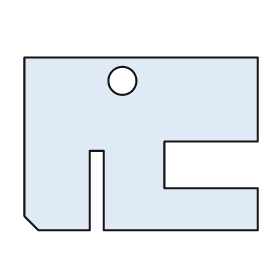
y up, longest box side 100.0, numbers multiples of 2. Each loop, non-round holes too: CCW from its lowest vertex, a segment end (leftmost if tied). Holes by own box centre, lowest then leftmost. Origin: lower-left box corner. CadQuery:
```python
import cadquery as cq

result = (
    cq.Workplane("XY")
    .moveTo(6.0, 0.0)
    .lineTo(28.0, 0.0)
    .lineTo(28.0, 34.0)
    .lineTo(34.0, 34.0)
    .lineTo(34.0, 0.0)
    .lineTo(100.0, 0.0)
    .lineTo(100.0, 18.0)
    .lineTo(60.0, 18.0)
    .lineTo(60.0, 38.0)
    .lineTo(100.0, 38.0)
    .lineTo(100.0, 74.0)
    .lineTo(0.0, 74.0)
    .lineTo(0.0, 6.0)
    .close()
    .moveTo(42.0, 64.0)
    .circle(6.0)
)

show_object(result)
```